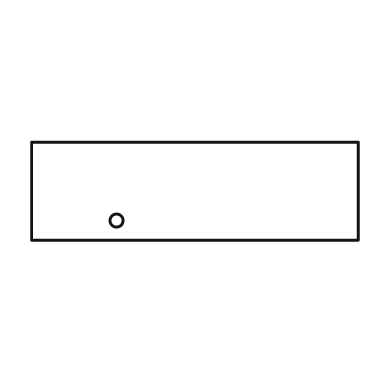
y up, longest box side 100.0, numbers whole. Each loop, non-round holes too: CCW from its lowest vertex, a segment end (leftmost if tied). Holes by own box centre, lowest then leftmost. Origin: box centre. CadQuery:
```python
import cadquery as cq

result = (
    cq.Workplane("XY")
    .moveTo(-50.0, -15.0)
    .lineTo(50.0, -15.0)
    .lineTo(50.0, 15.0)
    .lineTo(-50.0, 15.0)
    .close()
    .moveTo(-24.0, -9.0)
    .circle(2.0)
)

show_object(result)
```